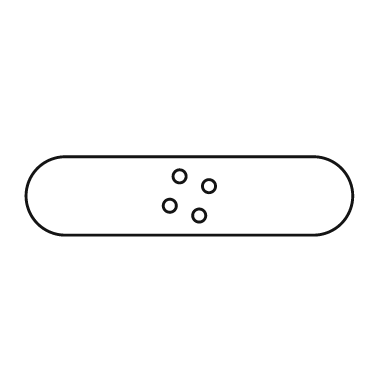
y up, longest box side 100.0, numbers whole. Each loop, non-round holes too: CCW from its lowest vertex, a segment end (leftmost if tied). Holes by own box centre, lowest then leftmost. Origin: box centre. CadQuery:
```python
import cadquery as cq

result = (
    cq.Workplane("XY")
    .moveTo(-38.0, -12.0)
    .lineTo(38.0, -12.0)
    .threePointArc((50.0, 0.0), (38.0, 12.0))
    .lineTo(-38.0, 12.0)
    .threePointArc((-50.0, 0.0), (-38.0, -12.0))
    .close()
    .moveTo(3.0, -6.0)
    .circle(2.0)
    .moveTo(-6.0, -3.0)
    .circle(2.0)
    .moveTo(6.0, 3.0)
    .circle(2.0)
    .moveTo(-3.0, 6.0)
    .circle(2.0)
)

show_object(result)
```